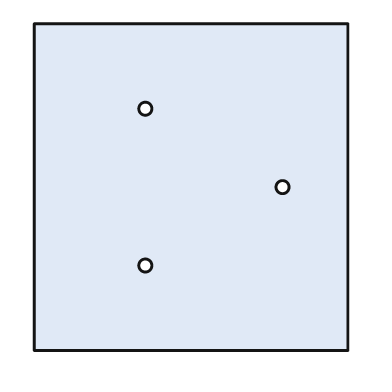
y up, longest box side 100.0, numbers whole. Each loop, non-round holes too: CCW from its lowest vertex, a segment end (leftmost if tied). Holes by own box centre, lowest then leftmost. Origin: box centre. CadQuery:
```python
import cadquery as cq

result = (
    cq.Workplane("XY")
    .moveTo(-48.0, -50.0)
    .lineTo(48.0, -50.0)
    .lineTo(48.0, 50.0)
    .lineTo(-48.0, 50.0)
    .close()
    .moveTo(-14.0, -24.0)
    .circle(2.0)
    .moveTo(28.0, 0.0)
    .circle(2.0)
    .moveTo(-14.0, 24.0)
    .circle(2.0)
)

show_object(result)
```